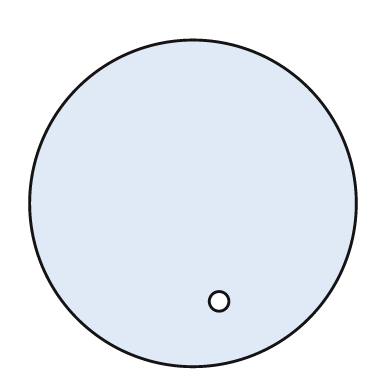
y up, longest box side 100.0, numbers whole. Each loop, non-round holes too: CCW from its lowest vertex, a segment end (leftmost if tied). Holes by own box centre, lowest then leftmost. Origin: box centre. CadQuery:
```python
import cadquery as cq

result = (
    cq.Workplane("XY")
    .moveTo(0.0, 0.0)
    .circle(50.0)
    .moveTo(8.0, -30.0)
    .circle(3.0)
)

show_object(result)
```